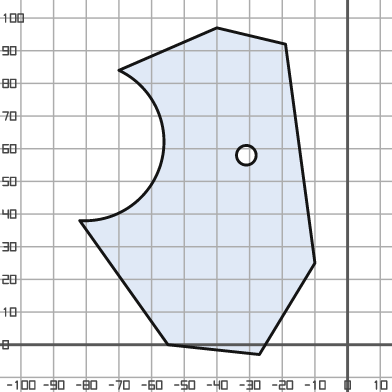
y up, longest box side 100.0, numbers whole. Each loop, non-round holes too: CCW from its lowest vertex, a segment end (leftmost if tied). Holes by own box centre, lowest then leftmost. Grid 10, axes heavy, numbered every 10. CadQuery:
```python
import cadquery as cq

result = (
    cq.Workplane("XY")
    .moveTo(-27.0, -3.0)
    .lineTo(-10.0, 25.0)
    .lineTo(-19.0, 92.0)
    .lineTo(-40.0, 97.0)
    .lineTo(-70.0, 84.0)
    .threePointArc((-57.0, 56.0), (-82.0, 38.0))
    .lineTo(-55.0, 0.0)
    .close()
    .moveTo(-31.0, 58.0)
    .circle(3.0)
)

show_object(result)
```